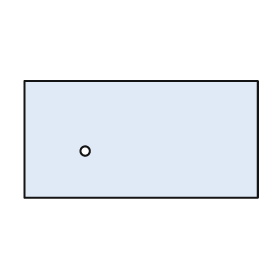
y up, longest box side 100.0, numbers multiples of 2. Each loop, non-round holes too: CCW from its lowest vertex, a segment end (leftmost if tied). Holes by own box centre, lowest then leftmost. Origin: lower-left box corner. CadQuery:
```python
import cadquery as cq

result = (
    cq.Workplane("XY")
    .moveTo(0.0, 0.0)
    .lineTo(100.0, 0.0)
    .lineTo(100.0, 50.0)
    .lineTo(0.0, 50.0)
    .close()
    .moveTo(26.0, 20.0)
    .circle(2.0)
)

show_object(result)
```